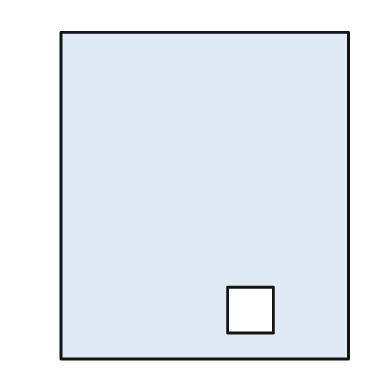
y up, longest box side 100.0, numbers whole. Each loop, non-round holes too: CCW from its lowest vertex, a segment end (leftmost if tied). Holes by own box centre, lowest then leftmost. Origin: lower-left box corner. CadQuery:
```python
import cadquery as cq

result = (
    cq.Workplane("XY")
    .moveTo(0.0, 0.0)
    .lineTo(88.0, 0.0)
    .lineTo(88.0, 100.0)
    .lineTo(0.0, 100.0)
    .close()
    .moveTo(51.0, 8.0)
    .lineTo(65.0, 8.0)
    .lineTo(65.0, 22.0)
    .lineTo(51.0, 22.0)
    .close()
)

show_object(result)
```